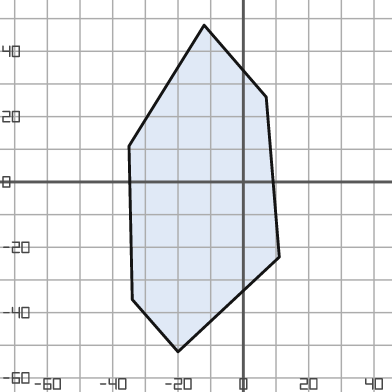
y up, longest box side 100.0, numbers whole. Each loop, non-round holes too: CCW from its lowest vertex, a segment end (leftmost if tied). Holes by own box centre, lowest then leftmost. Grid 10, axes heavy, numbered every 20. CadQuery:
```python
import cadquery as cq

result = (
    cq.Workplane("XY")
    .moveTo(-20.0, -52.0)
    .lineTo(11.0, -23.0)
    .lineTo(7.0, 26.0)
    .lineTo(-12.0, 48.0)
    .lineTo(-35.0, 11.0)
    .lineTo(-34.0, -36.0)
    .close()
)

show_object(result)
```